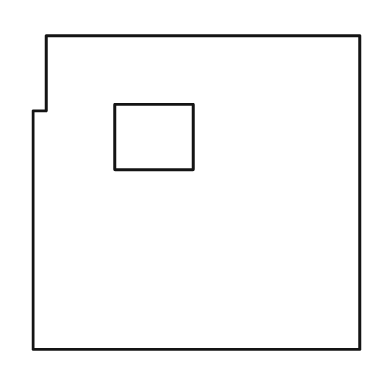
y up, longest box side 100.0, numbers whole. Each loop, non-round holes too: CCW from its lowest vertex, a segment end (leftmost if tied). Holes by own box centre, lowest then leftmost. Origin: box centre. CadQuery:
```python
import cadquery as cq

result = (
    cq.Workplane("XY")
    .moveTo(-50.0, -48.0)
    .lineTo(50.0, -48.0)
    .lineTo(50.0, 48.0)
    .lineTo(-46.0, 48.0)
    .lineTo(-46.0, 25.0)
    .lineTo(-50.0, 25.0)
    .close()
    .moveTo(-25.0, 7.0)
    .lineTo(-1.0, 7.0)
    .lineTo(-1.0, 27.0)
    .lineTo(-25.0, 27.0)
    .close()
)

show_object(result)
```